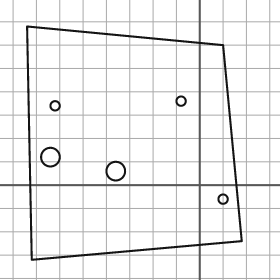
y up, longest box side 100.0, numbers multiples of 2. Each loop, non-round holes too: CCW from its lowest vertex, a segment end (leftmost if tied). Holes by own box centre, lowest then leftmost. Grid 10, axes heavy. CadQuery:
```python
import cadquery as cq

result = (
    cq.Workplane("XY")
    .moveTo(-72.0, -32.0)
    .lineTo(18.0, -24.0)
    .lineTo(10.0, 60.0)
    .lineTo(-74.0, 68.0)
    .close()
    .moveTo(10.0, -6.0)
    .circle(2.0)
    .moveTo(-36.0, 6.0)
    .circle(4.0)
    .moveTo(-64.0, 12.0)
    .circle(4.0)
    .moveTo(-62.0, 34.0)
    .circle(2.0)
    .moveTo(-8.0, 36.0)
    .circle(2.0)
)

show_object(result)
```